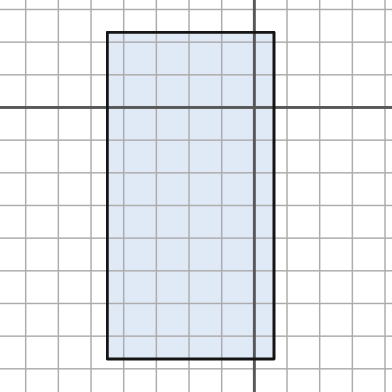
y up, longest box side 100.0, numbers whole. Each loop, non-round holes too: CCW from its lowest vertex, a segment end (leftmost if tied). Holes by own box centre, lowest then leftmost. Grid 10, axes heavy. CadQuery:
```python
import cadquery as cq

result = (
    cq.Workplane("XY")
    .moveTo(-45.0, -77.0)
    .lineTo(6.0, -77.0)
    .lineTo(6.0, 23.0)
    .lineTo(-45.0, 23.0)
    .close()
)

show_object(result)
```